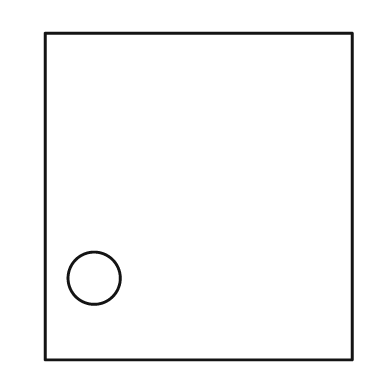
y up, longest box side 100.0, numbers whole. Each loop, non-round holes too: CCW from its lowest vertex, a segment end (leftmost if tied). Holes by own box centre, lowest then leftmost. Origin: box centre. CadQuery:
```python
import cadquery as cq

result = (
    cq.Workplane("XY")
    .moveTo(-47.0, -50.0)
    .lineTo(47.0, -50.0)
    .lineTo(47.0, 50.0)
    .lineTo(-47.0, 50.0)
    .close()
    .moveTo(-32.0, -25.0)
    .circle(8.0)
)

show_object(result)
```